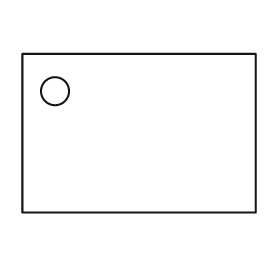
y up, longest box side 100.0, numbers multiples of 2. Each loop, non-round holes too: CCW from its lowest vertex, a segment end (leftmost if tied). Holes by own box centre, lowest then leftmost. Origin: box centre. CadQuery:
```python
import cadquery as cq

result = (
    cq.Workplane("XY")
    .moveTo(-50.0, -34.0)
    .lineTo(50.0, -34.0)
    .lineTo(50.0, 34.0)
    .lineTo(-50.0, 34.0)
    .close()
    .moveTo(-36.0, 18.0)
    .circle(6.0)
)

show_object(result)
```